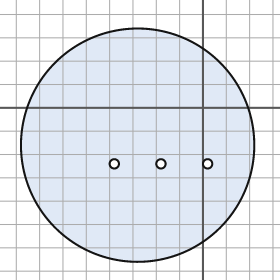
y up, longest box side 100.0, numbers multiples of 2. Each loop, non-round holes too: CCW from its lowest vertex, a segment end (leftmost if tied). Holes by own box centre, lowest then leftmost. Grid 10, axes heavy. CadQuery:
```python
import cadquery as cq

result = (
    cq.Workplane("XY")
    .moveTo(-28.0, -16.0)
    .circle(50.0)
    .moveTo(-38.0, -24.0)
    .circle(2.0)
    .moveTo(-18.0, -24.0)
    .circle(2.0)
    .moveTo(2.0, -24.0)
    .circle(2.0)
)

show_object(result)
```